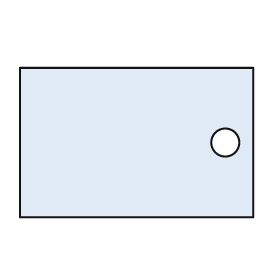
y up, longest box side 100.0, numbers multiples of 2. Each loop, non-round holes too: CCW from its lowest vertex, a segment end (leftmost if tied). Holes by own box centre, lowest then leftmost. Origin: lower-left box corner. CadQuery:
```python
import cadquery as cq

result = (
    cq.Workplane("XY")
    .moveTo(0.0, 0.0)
    .lineTo(100.0, 0.0)
    .lineTo(100.0, 64.0)
    .lineTo(0.0, 64.0)
    .close()
    .moveTo(88.0, 32.0)
    .circle(6.0)
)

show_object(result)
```